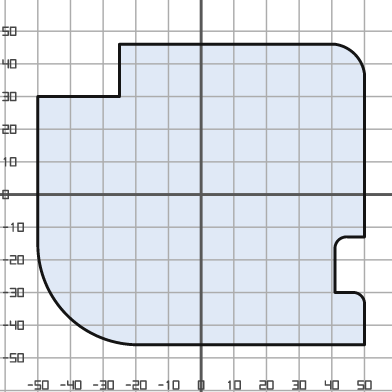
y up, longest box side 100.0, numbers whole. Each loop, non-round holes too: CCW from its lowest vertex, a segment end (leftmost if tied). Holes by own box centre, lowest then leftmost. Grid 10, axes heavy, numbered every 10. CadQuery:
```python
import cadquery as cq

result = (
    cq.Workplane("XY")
    .moveTo(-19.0, -46.0)
    .lineTo(50.0, -46.0)
    .lineTo(50.0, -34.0)
    .threePointArc((49.0, -31.0), (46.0, -30.0))
    .lineTo(41.0, -30.0)
    .lineTo(41.0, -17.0)
    .threePointArc((42.0, -14.0), (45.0, -13.0))
    .lineTo(50.0, -13.0)
    .lineTo(50.0, 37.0)
    .threePointArc((47.0, 43.0), (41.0, 46.0))
    .lineTo(-25.0, 46.0)
    .lineTo(-25.0, 30.0)
    .lineTo(-50.0, 30.0)
    .lineTo(-50.0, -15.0)
    .threePointArc((-41.0, -37.0), (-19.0, -46.0))
    .close()
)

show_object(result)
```